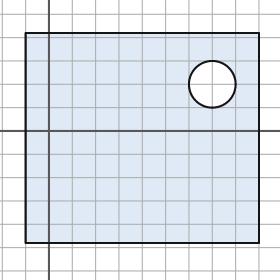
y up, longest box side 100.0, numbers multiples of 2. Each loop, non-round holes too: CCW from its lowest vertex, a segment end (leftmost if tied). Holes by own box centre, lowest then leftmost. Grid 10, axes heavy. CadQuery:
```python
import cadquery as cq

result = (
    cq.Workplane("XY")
    .moveTo(-10.0, -48.0)
    .lineTo(90.0, -48.0)
    .lineTo(90.0, 42.0)
    .lineTo(-10.0, 42.0)
    .close()
    .moveTo(70.0, 20.0)
    .circle(10.0)
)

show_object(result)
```